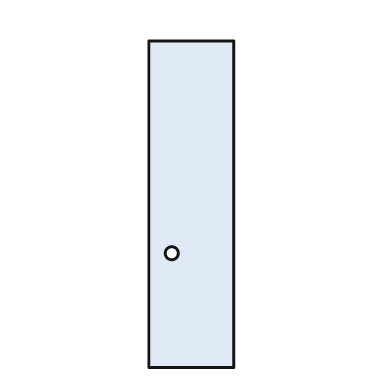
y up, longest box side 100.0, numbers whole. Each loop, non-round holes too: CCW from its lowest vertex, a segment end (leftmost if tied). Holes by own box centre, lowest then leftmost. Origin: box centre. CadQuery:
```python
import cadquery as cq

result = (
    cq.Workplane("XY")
    .moveTo(-13.0, -50.0)
    .lineTo(13.0, -50.0)
    .lineTo(13.0, 50.0)
    .lineTo(-13.0, 50.0)
    .close()
    .moveTo(-6.0, -15.0)
    .circle(2.0)
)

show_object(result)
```